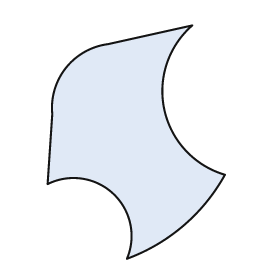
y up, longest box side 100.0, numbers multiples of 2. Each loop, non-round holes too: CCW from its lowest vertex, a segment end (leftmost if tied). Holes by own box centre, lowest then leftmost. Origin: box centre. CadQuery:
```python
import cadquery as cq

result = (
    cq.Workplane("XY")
    .moveTo(-4.0, -50.0)
    .threePointArc((20.0, -36.0), (38.0, -14.0))
    .threePointArc((12.0, 14.0), (24.0, 50.0))
    .lineTo(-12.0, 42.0)
    .threePointArc((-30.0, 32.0), (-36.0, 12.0))
    .lineTo(-38.0, -18.0)
    .threePointArc((-10.0, -22.0), (-4.0, -50.0))
    .close()
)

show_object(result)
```